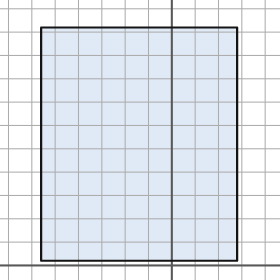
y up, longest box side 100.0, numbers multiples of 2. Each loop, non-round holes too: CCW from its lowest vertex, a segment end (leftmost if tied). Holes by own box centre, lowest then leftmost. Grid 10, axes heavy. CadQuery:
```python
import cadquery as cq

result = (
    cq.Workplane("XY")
    .moveTo(-56.0, 2.0)
    .lineTo(28.0, 2.0)
    .lineTo(28.0, 102.0)
    .lineTo(-56.0, 102.0)
    .close()
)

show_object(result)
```